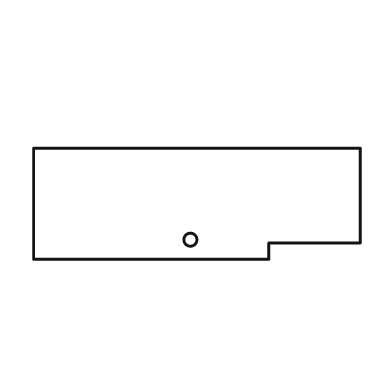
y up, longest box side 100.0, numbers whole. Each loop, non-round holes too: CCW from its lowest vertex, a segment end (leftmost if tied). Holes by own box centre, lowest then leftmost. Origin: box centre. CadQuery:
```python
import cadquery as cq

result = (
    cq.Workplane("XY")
    .moveTo(-50.0, -17.0)
    .lineTo(22.0, -17.0)
    .lineTo(22.0, -12.0)
    .lineTo(50.0, -12.0)
    .lineTo(50.0, 17.0)
    .lineTo(-50.0, 17.0)
    .close()
    .moveTo(-2.0, -11.0)
    .circle(2.0)
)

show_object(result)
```